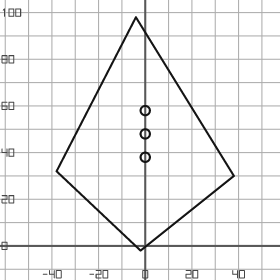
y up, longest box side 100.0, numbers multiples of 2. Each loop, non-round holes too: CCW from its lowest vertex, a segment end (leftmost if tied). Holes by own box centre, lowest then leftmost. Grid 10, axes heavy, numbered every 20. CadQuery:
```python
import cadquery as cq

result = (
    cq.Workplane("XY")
    .moveTo(-2.0, -2.0)
    .lineTo(38.0, 30.0)
    .lineTo(-4.0, 98.0)
    .lineTo(-38.0, 32.0)
    .close()
    .moveTo(0.0, 38.0)
    .circle(2.0)
    .moveTo(0.0, 48.0)
    .circle(2.0)
    .moveTo(0.0, 58.0)
    .circle(2.0)
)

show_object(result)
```